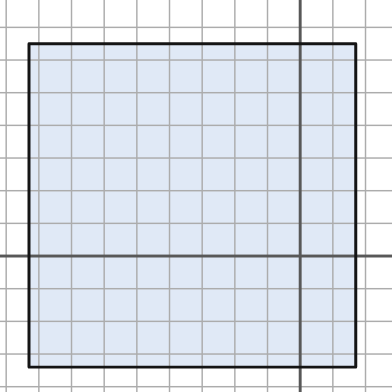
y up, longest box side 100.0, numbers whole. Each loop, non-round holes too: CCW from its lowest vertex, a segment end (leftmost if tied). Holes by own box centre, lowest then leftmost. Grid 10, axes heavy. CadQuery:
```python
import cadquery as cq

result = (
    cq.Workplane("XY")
    .moveTo(-83.0, -34.0)
    .lineTo(17.0, -34.0)
    .lineTo(17.0, 65.0)
    .lineTo(-83.0, 65.0)
    .close()
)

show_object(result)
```